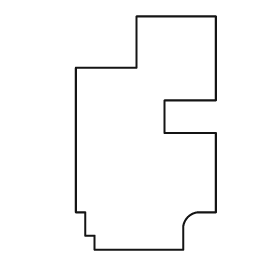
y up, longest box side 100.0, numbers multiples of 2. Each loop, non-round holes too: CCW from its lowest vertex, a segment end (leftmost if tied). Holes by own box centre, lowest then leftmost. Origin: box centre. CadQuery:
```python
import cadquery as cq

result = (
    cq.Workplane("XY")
    .moveTo(-22.0, -50.0)
    .lineTo(16.0, -50.0)
    .lineTo(16.0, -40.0)
    .threePointArc((18.0, -36.0), (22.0, -34.0))
    .lineTo(30.0, -34.0)
    .lineTo(30.0, 0.0)
    .lineTo(8.0, 0.0)
    .lineTo(8.0, 14.0)
    .lineTo(30.0, 14.0)
    .lineTo(30.0, 50.0)
    .lineTo(-4.0, 50.0)
    .lineTo(-4.0, 28.0)
    .lineTo(-30.0, 28.0)
    .lineTo(-30.0, -34.0)
    .lineTo(-26.0, -34.0)
    .lineTo(-26.0, -44.0)
    .lineTo(-22.0, -44.0)
    .close()
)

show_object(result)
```